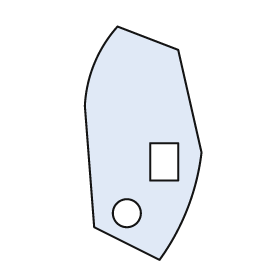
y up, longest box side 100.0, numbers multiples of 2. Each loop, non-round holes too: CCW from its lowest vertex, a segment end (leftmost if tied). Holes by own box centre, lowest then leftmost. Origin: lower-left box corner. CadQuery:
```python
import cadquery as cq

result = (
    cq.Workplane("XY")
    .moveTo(32.0, 0.0)
    .threePointArc((44.0, 22.0), (50.0, 46.0))
    .lineTo(40.0, 90.0)
    .lineTo(14.0, 100.0)
    .threePointArc((4.0, 84.0), (0.0, 66.0))
    .lineTo(4.0, 14.0)
    .close()
    .moveTo(18.0, 20.0)
    .circle(6.0)
    .moveTo(28.0, 34.0)
    .lineTo(40.0, 34.0)
    .lineTo(40.0, 50.0)
    .lineTo(28.0, 50.0)
    .close()
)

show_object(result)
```